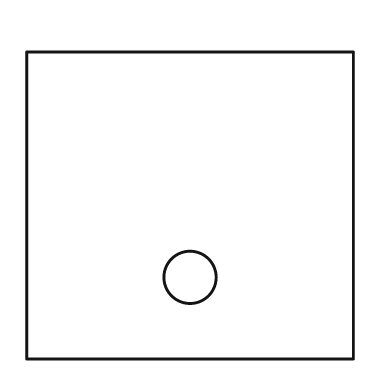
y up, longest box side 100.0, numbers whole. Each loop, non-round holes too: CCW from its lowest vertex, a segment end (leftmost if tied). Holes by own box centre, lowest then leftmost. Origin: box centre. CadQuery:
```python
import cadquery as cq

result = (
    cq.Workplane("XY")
    .moveTo(-50.0, -47.0)
    .lineTo(50.0, -47.0)
    .lineTo(50.0, 47.0)
    .lineTo(-50.0, 47.0)
    .close()
    .moveTo(0.0, -22.0)
    .circle(8.0)
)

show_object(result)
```